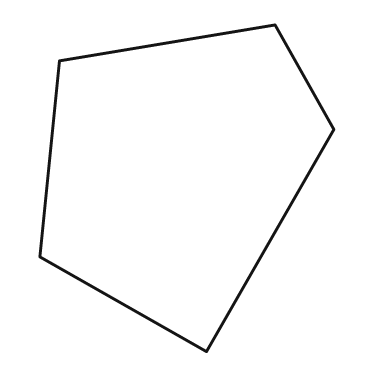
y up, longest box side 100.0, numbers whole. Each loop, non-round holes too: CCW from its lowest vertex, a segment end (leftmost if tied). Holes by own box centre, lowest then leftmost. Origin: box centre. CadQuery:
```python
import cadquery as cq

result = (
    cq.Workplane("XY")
    .moveTo(6.0, -50.0)
    .lineTo(45.0, 18.0)
    .lineTo(27.0, 50.0)
    .lineTo(-39.0, 39.0)
    .lineTo(-45.0, -21.0)
    .close()
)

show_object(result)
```